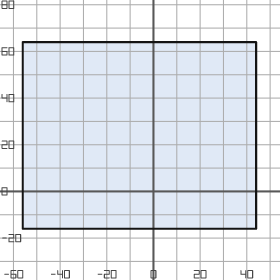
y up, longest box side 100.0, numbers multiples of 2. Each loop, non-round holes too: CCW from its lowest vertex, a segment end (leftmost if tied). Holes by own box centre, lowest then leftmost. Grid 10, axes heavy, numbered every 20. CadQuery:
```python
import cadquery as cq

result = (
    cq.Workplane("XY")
    .moveTo(-56.0, -16.0)
    .lineTo(44.0, -16.0)
    .lineTo(44.0, 64.0)
    .lineTo(-56.0, 64.0)
    .close()
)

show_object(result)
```